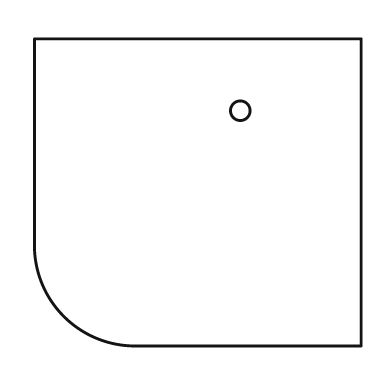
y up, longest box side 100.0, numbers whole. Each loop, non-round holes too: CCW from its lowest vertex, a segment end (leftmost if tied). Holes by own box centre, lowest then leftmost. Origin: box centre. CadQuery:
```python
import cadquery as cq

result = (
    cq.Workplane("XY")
    .moveTo(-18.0, -47.0)
    .lineTo(50.0, -47.0)
    .lineTo(50.0, 47.0)
    .lineTo(-50.0, 47.0)
    .lineTo(-50.0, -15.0)
    .threePointArc((-41.0, -38.0), (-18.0, -47.0))
    .close()
    .moveTo(13.0, 25.0)
    .circle(3.0)
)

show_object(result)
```